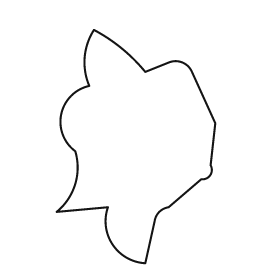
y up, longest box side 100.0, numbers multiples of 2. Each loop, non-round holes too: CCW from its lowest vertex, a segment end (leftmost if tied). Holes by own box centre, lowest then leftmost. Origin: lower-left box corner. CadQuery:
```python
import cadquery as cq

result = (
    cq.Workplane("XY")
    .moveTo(38.0, 0.0)
    .lineTo(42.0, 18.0)
    .threePointArc((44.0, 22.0), (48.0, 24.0))
    .lineTo(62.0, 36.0)
    .threePointArc((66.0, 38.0), (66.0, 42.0))
    .lineTo(68.0, 60.0)
    .lineTo(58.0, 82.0)
    .threePointArc((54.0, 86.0), (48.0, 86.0))
    .lineTo(38.0, 82.0)
    .threePointArc((28.0, 92.0), (16.0, 100.0))
    .threePointArc((12.0, 88.0), (14.0, 76.0))
    .threePointArc((2.0, 64.0), (8.0, 48.0))
    .threePointArc((8.0, 34.0), (0.0, 22.0))
    .lineTo(22.0, 24.0)
    .threePointArc((24.0, 8.0), (38.0, 0.0))
    .close()
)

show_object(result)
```